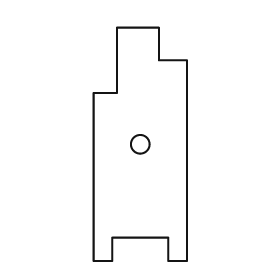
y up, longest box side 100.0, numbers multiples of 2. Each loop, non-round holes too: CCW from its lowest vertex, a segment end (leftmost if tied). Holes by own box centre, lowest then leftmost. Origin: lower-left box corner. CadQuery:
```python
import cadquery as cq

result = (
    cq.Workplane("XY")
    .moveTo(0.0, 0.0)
    .lineTo(8.0, 0.0)
    .lineTo(8.0, 10.0)
    .lineTo(32.0, 10.0)
    .lineTo(32.0, 0.0)
    .lineTo(40.0, 0.0)
    .lineTo(40.0, 86.0)
    .lineTo(28.0, 86.0)
    .lineTo(28.0, 100.0)
    .lineTo(10.0, 100.0)
    .lineTo(10.0, 72.0)
    .lineTo(0.0, 72.0)
    .close()
    .moveTo(20.0, 50.0)
    .circle(4.0)
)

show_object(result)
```